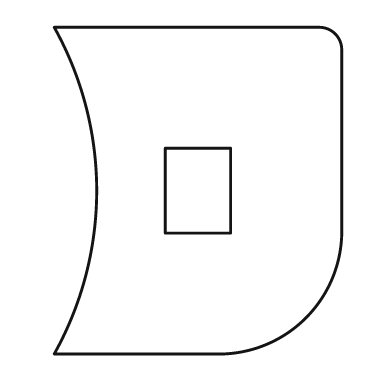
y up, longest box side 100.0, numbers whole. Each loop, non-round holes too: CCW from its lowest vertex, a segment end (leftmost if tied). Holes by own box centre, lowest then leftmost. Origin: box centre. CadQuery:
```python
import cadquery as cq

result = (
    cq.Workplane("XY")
    .moveTo(-44.0, -50.0)
    .lineTo(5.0, -50.0)
    .threePointArc((33.0, -39.0), (44.0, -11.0))
    .lineTo(44.0, 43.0)
    .threePointArc((42.0, 48.0), (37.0, 50.0))
    .lineTo(-44.0, 50.0)
    .threePointArc((-31.0, 0.0), (-44.0, -50.0))
    .close()
    .moveTo(-10.0, -13.0)
    .lineTo(10.0, -13.0)
    .lineTo(10.0, 13.0)
    .lineTo(-10.0, 13.0)
    .close()
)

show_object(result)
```